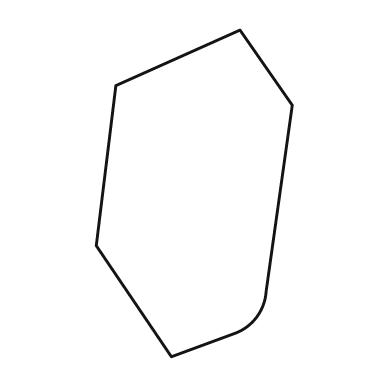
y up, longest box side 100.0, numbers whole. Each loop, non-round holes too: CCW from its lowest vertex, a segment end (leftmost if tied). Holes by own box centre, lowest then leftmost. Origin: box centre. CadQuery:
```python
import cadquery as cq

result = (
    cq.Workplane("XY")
    .moveTo(-7.0, -50.0)
    .lineTo(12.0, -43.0)
    .threePointArc((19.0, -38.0), (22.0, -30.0))
    .lineTo(30.0, 27.0)
    .lineTo(14.0, 50.0)
    .lineTo(-24.0, 33.0)
    .lineTo(-30.0, -16.0)
    .close()
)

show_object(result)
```